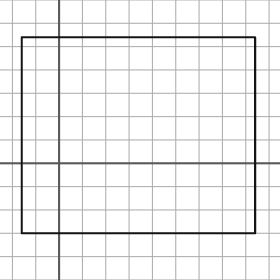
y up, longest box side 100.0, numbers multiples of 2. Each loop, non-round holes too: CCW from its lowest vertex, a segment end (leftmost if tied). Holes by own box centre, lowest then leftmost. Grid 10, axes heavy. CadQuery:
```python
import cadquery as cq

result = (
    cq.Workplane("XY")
    .moveTo(-16.0, -30.0)
    .lineTo(84.0, -30.0)
    .lineTo(84.0, 54.0)
    .lineTo(-16.0, 54.0)
    .close()
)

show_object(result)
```